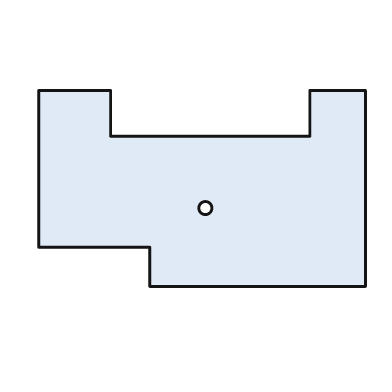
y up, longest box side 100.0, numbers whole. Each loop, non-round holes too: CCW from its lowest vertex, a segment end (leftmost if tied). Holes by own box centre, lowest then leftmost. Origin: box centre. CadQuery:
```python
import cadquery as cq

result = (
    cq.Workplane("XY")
    .moveTo(-16.0, -30.0)
    .lineTo(50.0, -30.0)
    .lineTo(50.0, 30.0)
    .lineTo(33.0, 30.0)
    .lineTo(33.0, 16.0)
    .lineTo(-28.0, 16.0)
    .lineTo(-28.0, 30.0)
    .lineTo(-50.0, 30.0)
    .lineTo(-50.0, -18.0)
    .lineTo(-16.0, -18.0)
    .close()
    .moveTo(1.0, -6.0)
    .circle(2.0)
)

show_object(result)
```